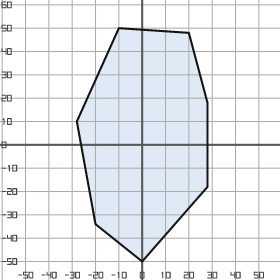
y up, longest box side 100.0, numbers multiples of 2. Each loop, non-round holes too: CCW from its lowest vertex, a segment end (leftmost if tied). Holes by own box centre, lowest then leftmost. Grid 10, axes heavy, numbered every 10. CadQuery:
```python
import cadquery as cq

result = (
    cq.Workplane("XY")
    .moveTo(0.0, -50.0)
    .lineTo(28.0, -18.0)
    .lineTo(28.0, 18.0)
    .lineTo(20.0, 48.0)
    .lineTo(-10.0, 50.0)
    .lineTo(-28.0, 10.0)
    .lineTo(-20.0, -34.0)
    .close()
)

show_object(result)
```